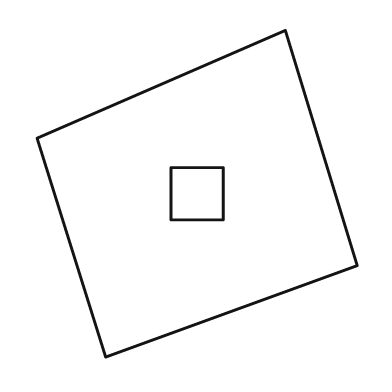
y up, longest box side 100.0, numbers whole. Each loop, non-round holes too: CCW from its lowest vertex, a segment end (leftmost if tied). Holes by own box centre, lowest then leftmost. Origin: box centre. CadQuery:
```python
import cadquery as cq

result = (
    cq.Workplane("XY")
    .moveTo(-28.0, -50.0)
    .lineTo(49.0, -22.0)
    .lineTo(27.0, 50.0)
    .lineTo(-49.0, 17.0)
    .close()
    .moveTo(-8.0, -8.0)
    .lineTo(8.0, -8.0)
    .lineTo(8.0, 8.0)
    .lineTo(-8.0, 8.0)
    .close()
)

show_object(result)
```